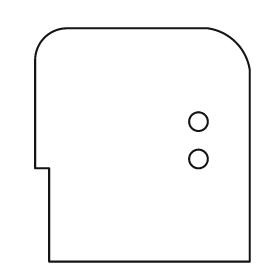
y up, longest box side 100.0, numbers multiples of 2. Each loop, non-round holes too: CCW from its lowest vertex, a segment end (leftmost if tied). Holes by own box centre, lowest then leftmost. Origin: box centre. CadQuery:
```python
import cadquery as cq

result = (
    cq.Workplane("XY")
    .moveTo(-40.0, -50.0)
    .lineTo(46.0, -50.0)
    .lineTo(46.0, 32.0)
    .threePointArc((40.0, 44.0), (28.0, 50.0))
    .lineTo(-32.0, 50.0)
    .threePointArc((-42.0, 46.0), (-46.0, 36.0))
    .lineTo(-46.0, -10.0)
    .lineTo(-40.0, -10.0)
    .close()
    .moveTo(24.0, -6.0)
    .circle(4.0)
    .moveTo(24.0, 10.0)
    .circle(4.0)
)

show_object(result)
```